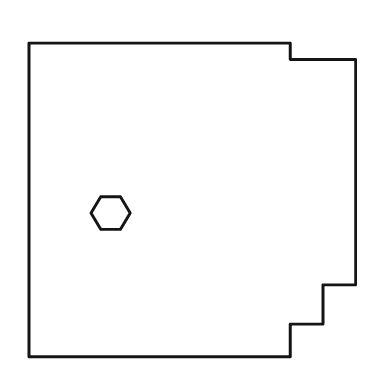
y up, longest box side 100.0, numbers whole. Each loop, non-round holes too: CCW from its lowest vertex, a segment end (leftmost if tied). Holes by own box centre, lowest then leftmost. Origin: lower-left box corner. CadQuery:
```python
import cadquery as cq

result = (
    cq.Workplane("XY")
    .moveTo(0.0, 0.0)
    .lineTo(80.0, 0.0)
    .lineTo(80.0, 10.0)
    .lineTo(90.0, 10.0)
    .lineTo(90.0, 22.0)
    .lineTo(100.0, 22.0)
    .lineTo(100.0, 91.0)
    .lineTo(80.0, 91.0)
    .lineTo(80.0, 96.0)
    .lineTo(0.0, 96.0)
    .close()
    .moveTo(22.0, 39.0)
    .lineTo(28.0, 39.0)
    .lineTo(31.0, 44.0)
    .lineTo(28.0, 49.0)
    .lineTo(22.0, 49.0)
    .lineTo(19.0, 44.0)
    .close()
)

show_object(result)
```